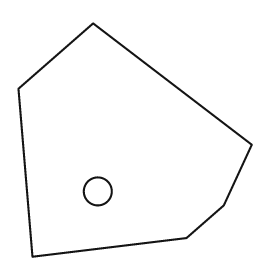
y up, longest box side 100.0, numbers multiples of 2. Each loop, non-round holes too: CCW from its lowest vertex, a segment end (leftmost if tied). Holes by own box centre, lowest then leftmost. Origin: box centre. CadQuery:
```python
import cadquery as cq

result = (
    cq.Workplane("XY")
    .moveTo(-44.0, -50.0)
    .lineTo(22.0, -42.0)
    .lineTo(38.0, -28.0)
    .lineTo(50.0, -2.0)
    .lineTo(-18.0, 50.0)
    .lineTo(-50.0, 22.0)
    .close()
    .moveTo(-16.0, -22.0)
    .circle(6.0)
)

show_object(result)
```